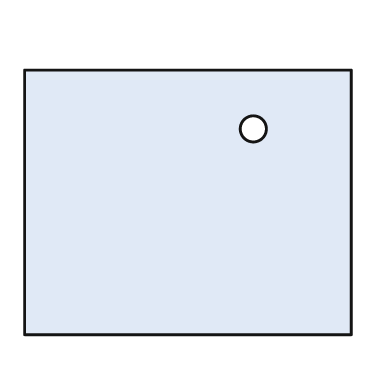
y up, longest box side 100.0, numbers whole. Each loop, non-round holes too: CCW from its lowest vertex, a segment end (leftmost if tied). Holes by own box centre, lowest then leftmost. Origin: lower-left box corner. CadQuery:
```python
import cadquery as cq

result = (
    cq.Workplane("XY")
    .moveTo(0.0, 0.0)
    .lineTo(100.0, 0.0)
    .lineTo(100.0, 81.0)
    .lineTo(0.0, 81.0)
    .close()
    .moveTo(70.0, 63.0)
    .circle(4.0)
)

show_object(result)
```